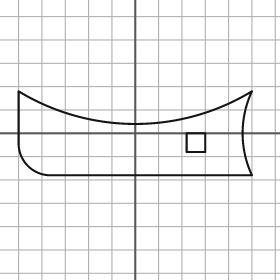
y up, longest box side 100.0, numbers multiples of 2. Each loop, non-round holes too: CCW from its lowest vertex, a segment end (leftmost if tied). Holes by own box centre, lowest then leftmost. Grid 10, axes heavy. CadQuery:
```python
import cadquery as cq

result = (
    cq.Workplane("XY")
    .moveTo(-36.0, -18.0)
    .lineTo(50.0, -18.0)
    .threePointArc((46.0, 0.0), (50.0, 18.0))
    .threePointArc((0.0, 4.0), (-50.0, 18.0))
    .lineTo(-50.0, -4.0)
    .threePointArc((-46.0, -14.0), (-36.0, -18.0))
    .close()
    .moveTo(22.0, -8.0)
    .lineTo(30.0, -8.0)
    .lineTo(30.0, 0.0)
    .lineTo(22.0, 0.0)
    .close()
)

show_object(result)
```